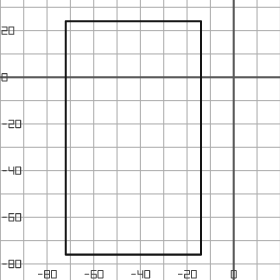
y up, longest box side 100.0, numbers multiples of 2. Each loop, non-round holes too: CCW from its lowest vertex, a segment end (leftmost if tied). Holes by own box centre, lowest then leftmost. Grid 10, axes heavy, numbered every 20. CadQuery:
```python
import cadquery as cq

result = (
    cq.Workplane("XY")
    .moveTo(-72.0, -76.0)
    .lineTo(-14.0, -76.0)
    .lineTo(-14.0, 24.0)
    .lineTo(-72.0, 24.0)
    .close()
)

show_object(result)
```